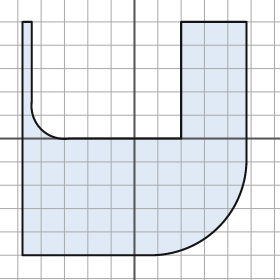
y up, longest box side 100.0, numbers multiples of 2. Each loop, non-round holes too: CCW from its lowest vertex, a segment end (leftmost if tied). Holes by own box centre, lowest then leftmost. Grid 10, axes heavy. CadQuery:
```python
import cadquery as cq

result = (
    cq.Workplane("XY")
    .moveTo(-48.0, -50.0)
    .lineTo(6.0, -50.0)
    .threePointArc((36.0, -38.0), (48.0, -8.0))
    .lineTo(48.0, 50.0)
    .lineTo(20.0, 50.0)
    .lineTo(20.0, 0.0)
    .lineTo(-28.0, 0.0)
    .threePointArc((-40.0, 4.0), (-44.0, 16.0))
    .lineTo(-44.0, 50.0)
    .lineTo(-48.0, 50.0)
    .close()
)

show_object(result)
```